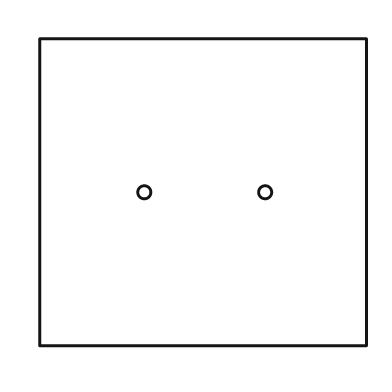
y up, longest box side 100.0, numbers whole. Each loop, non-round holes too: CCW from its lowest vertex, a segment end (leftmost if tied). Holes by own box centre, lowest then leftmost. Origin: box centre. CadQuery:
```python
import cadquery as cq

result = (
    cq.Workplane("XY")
    .moveTo(-50.0, -47.0)
    .lineTo(50.0, -47.0)
    .lineTo(50.0, 47.0)
    .lineTo(-50.0, 47.0)
    .close()
    .moveTo(-18.0, 0.0)
    .circle(2.0)
    .moveTo(19.0, 0.0)
    .circle(2.0)
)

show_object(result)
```